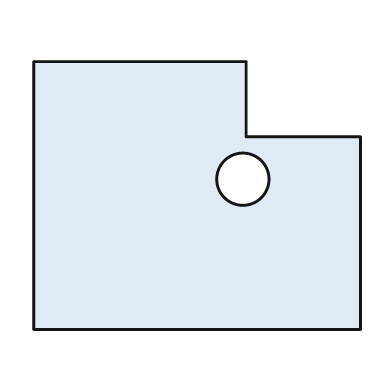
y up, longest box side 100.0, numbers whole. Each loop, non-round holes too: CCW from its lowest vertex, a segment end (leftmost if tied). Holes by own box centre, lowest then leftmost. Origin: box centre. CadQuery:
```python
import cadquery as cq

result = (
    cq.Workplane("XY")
    .moveTo(-50.0, -41.0)
    .lineTo(50.0, -41.0)
    .lineTo(50.0, 18.0)
    .lineTo(15.0, 18.0)
    .lineTo(15.0, 41.0)
    .lineTo(-50.0, 41.0)
    .close()
    .moveTo(14.0, 5.0)
    .circle(8.0)
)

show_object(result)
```